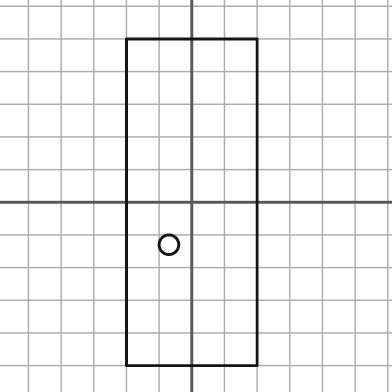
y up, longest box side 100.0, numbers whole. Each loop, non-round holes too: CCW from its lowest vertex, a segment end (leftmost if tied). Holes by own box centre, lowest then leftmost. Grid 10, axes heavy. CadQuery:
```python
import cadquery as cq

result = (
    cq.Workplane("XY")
    .moveTo(-20.0, -50.0)
    .lineTo(20.0, -50.0)
    .lineTo(20.0, 50.0)
    .lineTo(-20.0, 50.0)
    .close()
    .moveTo(-7.0, -13.0)
    .circle(3.0)
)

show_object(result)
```